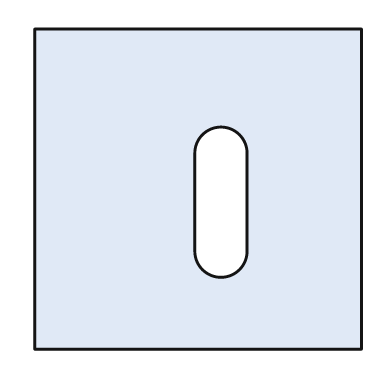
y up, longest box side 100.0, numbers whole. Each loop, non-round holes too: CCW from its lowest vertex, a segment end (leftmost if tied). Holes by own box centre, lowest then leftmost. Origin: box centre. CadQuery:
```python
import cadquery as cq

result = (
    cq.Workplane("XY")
    .moveTo(-50.0, -49.0)
    .lineTo(50.0, -49.0)
    .lineTo(50.0, 49.0)
    .lineTo(-50.0, 49.0)
    .close()
    .moveTo(-1.0, -19.0)
    .threePointArc((7.0, -27.0), (15.0, -19.0))
    .lineTo(15.0, 11.0)
    .threePointArc((7.0, 19.0), (-1.0, 11.0))
    .close()
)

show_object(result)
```